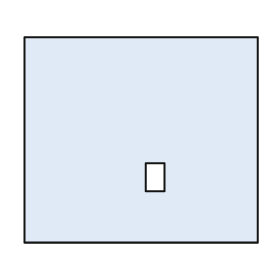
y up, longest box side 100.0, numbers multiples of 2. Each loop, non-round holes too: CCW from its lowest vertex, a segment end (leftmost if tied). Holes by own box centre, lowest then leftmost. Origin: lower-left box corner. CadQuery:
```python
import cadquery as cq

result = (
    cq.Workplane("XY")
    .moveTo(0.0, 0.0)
    .lineTo(100.0, 0.0)
    .lineTo(100.0, 88.0)
    .lineTo(0.0, 88.0)
    .close()
    .moveTo(52.0, 22.0)
    .lineTo(60.0, 22.0)
    .lineTo(60.0, 34.0)
    .lineTo(52.0, 34.0)
    .close()
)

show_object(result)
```